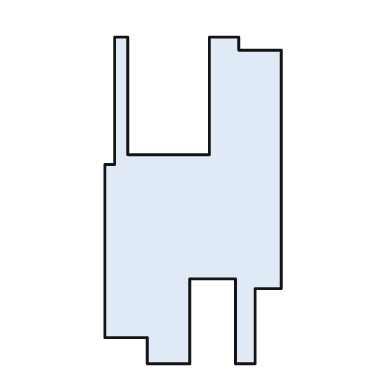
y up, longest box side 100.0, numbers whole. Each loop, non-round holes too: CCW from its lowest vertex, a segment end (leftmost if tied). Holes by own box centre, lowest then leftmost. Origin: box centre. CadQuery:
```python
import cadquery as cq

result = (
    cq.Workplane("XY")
    .moveTo(-14.0, -50.0)
    .lineTo(-1.0, -50.0)
    .lineTo(-1.0, -24.0)
    .lineTo(13.0, -24.0)
    .lineTo(13.0, -50.0)
    .lineTo(19.0, -50.0)
    .lineTo(19.0, -27.0)
    .lineTo(27.0, -27.0)
    .lineTo(27.0, 46.0)
    .lineTo(14.0, 46.0)
    .lineTo(14.0, 50.0)
    .lineTo(5.0, 50.0)
    .lineTo(5.0, 14.0)
    .lineTo(-20.0, 14.0)
    .lineTo(-20.0, 50.0)
    .lineTo(-24.0, 50.0)
    .lineTo(-24.0, 11.0)
    .lineTo(-27.0, 11.0)
    .lineTo(-27.0, -42.0)
    .lineTo(-14.0, -42.0)
    .close()
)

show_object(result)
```